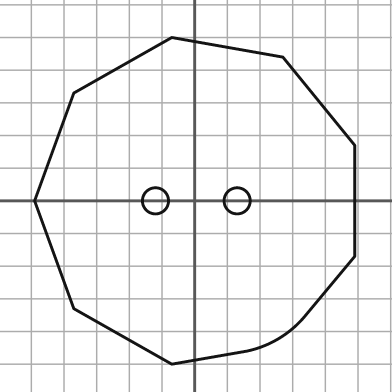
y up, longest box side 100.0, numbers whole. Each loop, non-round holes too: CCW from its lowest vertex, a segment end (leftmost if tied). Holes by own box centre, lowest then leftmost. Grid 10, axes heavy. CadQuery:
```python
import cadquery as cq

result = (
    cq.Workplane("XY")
    .moveTo(-7.0, -50.0)
    .lineTo(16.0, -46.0)
    .threePointArc((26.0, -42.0), (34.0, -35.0))
    .lineTo(49.0, -17.0)
    .lineTo(49.0, 17.0)
    .lineTo(27.0, 44.0)
    .lineTo(-7.0, 50.0)
    .lineTo(-37.0, 33.0)
    .lineTo(-49.0, 0.0)
    .lineTo(-37.0, -33.0)
    .close()
    .moveTo(-12.0, 0.0)
    .circle(4.0)
    .moveTo(13.0, 0.0)
    .circle(4.0)
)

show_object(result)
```